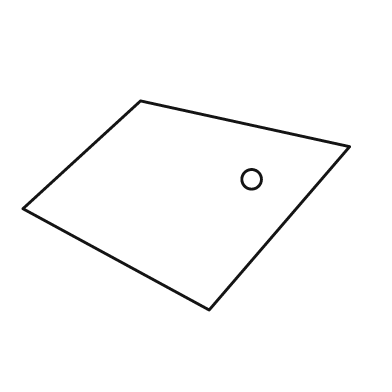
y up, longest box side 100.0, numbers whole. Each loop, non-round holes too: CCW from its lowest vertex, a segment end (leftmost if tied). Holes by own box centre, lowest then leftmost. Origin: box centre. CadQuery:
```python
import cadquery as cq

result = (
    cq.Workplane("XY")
    .moveTo(7.0, -32.0)
    .lineTo(50.0, 18.0)
    .lineTo(-14.0, 32.0)
    .lineTo(-50.0, -1.0)
    .close()
    .moveTo(20.0, 8.0)
    .circle(3.0)
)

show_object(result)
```